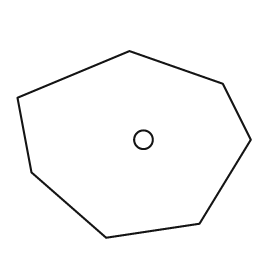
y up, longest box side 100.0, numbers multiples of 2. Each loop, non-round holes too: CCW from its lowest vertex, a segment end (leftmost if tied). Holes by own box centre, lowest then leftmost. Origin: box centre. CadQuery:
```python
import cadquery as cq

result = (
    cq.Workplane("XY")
    .moveTo(-12.0, -40.0)
    .lineTo(28.0, -34.0)
    .lineTo(50.0, 2.0)
    .lineTo(38.0, 26.0)
    .lineTo(-2.0, 40.0)
    .lineTo(-50.0, 20.0)
    .lineTo(-44.0, -12.0)
    .close()
    .moveTo(4.0, 2.0)
    .circle(4.0)
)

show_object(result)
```